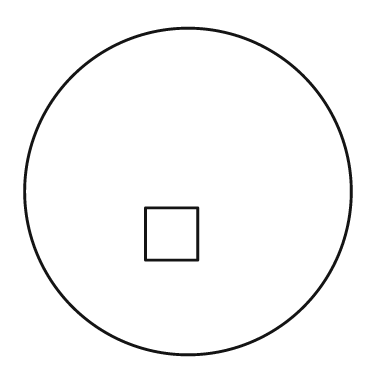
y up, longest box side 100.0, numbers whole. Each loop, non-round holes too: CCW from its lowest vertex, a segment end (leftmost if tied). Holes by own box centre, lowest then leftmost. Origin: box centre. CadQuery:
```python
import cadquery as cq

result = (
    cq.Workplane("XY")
    .moveTo(0.0, 0.0)
    .circle(50.0)
    .moveTo(-13.0, -21.0)
    .lineTo(3.0, -21.0)
    .lineTo(3.0, -5.0)
    .lineTo(-13.0, -5.0)
    .close()
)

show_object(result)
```